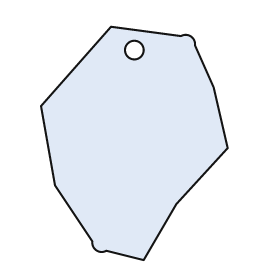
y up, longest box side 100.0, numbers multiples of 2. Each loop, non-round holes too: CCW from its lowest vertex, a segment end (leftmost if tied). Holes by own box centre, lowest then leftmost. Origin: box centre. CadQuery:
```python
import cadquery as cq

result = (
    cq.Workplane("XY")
    .moveTo(4.0, -50.0)
    .lineTo(18.0, -26.0)
    .lineTo(40.0, -2.0)
    .lineTo(34.0, 24.0)
    .lineTo(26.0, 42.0)
    .threePointArc((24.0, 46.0), (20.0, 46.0))
    .lineTo(-10.0, 50.0)
    .lineTo(-40.0, 16.0)
    .lineTo(-34.0, -18.0)
    .lineTo(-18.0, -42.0)
    .threePointArc((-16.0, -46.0), (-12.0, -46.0))
    .close()
    .moveTo(0.0, 40.0)
    .circle(4.0)
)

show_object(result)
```